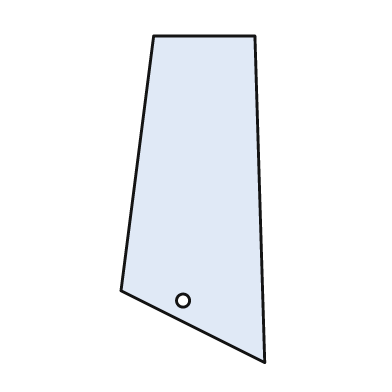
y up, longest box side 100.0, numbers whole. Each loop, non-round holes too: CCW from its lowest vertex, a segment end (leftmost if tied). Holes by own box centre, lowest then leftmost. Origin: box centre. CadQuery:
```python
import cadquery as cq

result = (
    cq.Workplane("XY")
    .moveTo(22.0, -50.0)
    .lineTo(19.0, 50.0)
    .lineTo(-12.0, 50.0)
    .lineTo(-22.0, -28.0)
    .close()
    .moveTo(-3.0, -31.0)
    .circle(2.0)
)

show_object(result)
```